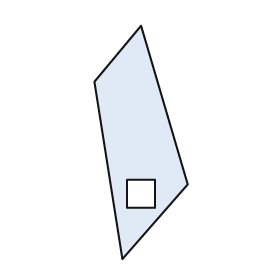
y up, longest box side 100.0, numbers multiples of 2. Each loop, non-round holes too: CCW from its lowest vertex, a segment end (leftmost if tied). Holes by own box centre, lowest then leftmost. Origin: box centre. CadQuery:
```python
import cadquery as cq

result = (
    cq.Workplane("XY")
    .moveTo(-8.0, -50.0)
    .lineTo(20.0, -18.0)
    .lineTo(0.0, 50.0)
    .lineTo(-20.0, 26.0)
    .close()
    .moveTo(-6.0, -28.0)
    .lineTo(6.0, -28.0)
    .lineTo(6.0, -16.0)
    .lineTo(-6.0, -16.0)
    .close()
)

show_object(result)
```